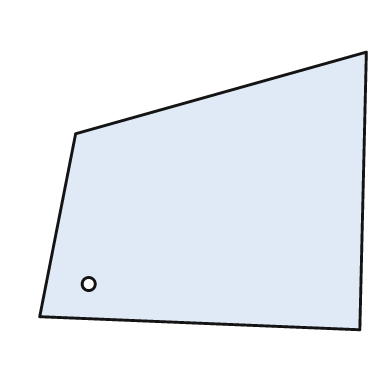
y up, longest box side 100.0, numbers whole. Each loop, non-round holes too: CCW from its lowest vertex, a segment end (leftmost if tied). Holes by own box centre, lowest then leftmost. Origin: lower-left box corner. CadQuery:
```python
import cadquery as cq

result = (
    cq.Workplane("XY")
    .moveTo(98.0, 0.0)
    .lineTo(100.0, 85.0)
    .lineTo(11.0, 60.0)
    .lineTo(0.0, 4.0)
    .close()
    .moveTo(15.0, 14.0)
    .circle(2.0)
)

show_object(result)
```